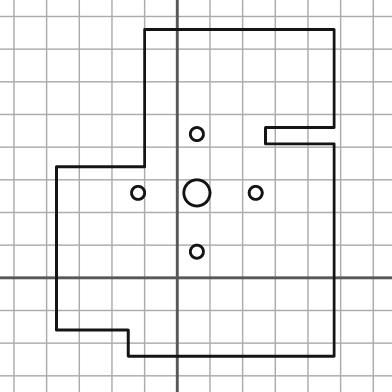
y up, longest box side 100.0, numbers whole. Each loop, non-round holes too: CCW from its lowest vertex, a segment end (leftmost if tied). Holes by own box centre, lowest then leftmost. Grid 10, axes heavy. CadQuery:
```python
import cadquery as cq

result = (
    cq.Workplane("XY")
    .moveTo(-15.0, -24.0)
    .lineTo(48.0, -24.0)
    .lineTo(48.0, 41.0)
    .lineTo(27.0, 41.0)
    .lineTo(27.0, 46.0)
    .lineTo(48.0, 46.0)
    .lineTo(48.0, 76.0)
    .lineTo(-10.0, 76.0)
    .lineTo(-10.0, 34.0)
    .lineTo(-37.0, 34.0)
    .lineTo(-37.0, -16.0)
    .lineTo(-15.0, -16.0)
    .close()
    .moveTo(6.0, 8.0)
    .circle(2.0)
    .moveTo(-12.0, 26.0)
    .circle(2.0)
    .moveTo(6.0, 26.0)
    .circle(4.0)
    .moveTo(24.0, 26.0)
    .circle(2.0)
    .moveTo(6.0, 44.0)
    .circle(2.0)
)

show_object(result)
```